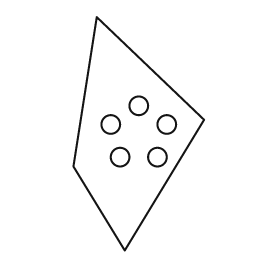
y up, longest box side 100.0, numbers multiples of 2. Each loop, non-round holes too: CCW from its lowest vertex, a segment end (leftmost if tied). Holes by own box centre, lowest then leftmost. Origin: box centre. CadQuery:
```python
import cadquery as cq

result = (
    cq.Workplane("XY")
    .moveTo(-6.0, -50.0)
    .lineTo(28.0, 6.0)
    .lineTo(-18.0, 50.0)
    .lineTo(-28.0, -14.0)
    .close()
    .moveTo(-8.0, -10.0)
    .circle(4.0)
    .moveTo(8.0, -10.0)
    .circle(4.0)
    .moveTo(-12.0, 4.0)
    .circle(4.0)
    .moveTo(12.0, 4.0)
    .circle(4.0)
    .moveTo(0.0, 12.0)
    .circle(4.0)
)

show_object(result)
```